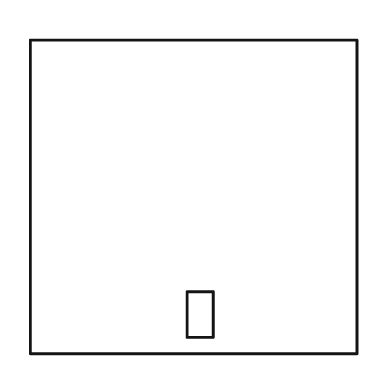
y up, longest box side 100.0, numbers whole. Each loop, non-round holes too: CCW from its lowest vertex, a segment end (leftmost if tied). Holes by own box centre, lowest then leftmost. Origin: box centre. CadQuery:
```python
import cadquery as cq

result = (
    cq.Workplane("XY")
    .moveTo(-50.0, -48.0)
    .lineTo(50.0, -48.0)
    .lineTo(50.0, 48.0)
    .lineTo(-50.0, 48.0)
    .close()
    .moveTo(-2.0, -43.0)
    .lineTo(6.0, -43.0)
    .lineTo(6.0, -29.0)
    .lineTo(-2.0, -29.0)
    .close()
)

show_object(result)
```